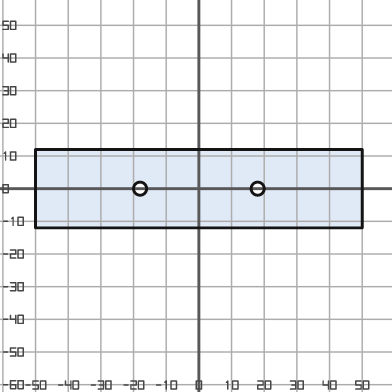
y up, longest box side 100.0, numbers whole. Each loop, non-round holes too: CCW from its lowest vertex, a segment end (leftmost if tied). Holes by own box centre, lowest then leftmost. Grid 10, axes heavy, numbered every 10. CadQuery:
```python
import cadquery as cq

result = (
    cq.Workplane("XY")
    .moveTo(-50.0, -12.0)
    .lineTo(50.0, -12.0)
    .lineTo(50.0, 12.0)
    .lineTo(-50.0, 12.0)
    .close()
    .moveTo(-18.0, 0.0)
    .circle(2.0)
    .moveTo(18.0, 0.0)
    .circle(2.0)
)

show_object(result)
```